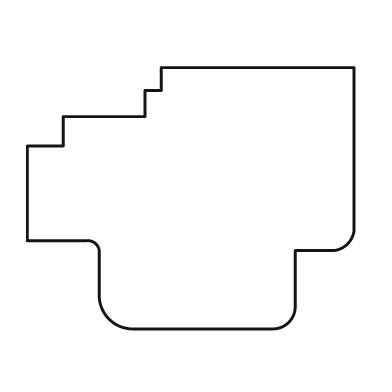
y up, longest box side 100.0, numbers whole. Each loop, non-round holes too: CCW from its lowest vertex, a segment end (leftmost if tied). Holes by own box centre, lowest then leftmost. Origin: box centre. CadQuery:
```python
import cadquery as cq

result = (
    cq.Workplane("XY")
    .moveTo(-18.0, -40.0)
    .lineTo(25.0, -40.0)
    .threePointArc((30.0, -38.0), (32.0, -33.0))
    .lineTo(32.0, -16.0)
    .lineTo(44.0, -16.0)
    .threePointArc((48.0, -14.0), (50.0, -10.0))
    .lineTo(50.0, 40.0)
    .lineTo(-9.0, 40.0)
    .lineTo(-9.0, 33.0)
    .lineTo(-14.0, 33.0)
    .lineTo(-14.0, 25.0)
    .lineTo(-39.0, 25.0)
    .lineTo(-39.0, 16.0)
    .lineTo(-50.0, 16.0)
    .lineTo(-50.0, -13.0)
    .lineTo(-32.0, -13.0)
    .threePointArc((-29.0, -14.0), (-28.0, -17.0))
    .lineTo(-28.0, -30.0)
    .threePointArc((-25.0, -37.0), (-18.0, -40.0))
    .close()
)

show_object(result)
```